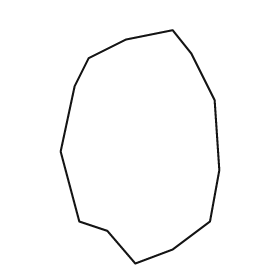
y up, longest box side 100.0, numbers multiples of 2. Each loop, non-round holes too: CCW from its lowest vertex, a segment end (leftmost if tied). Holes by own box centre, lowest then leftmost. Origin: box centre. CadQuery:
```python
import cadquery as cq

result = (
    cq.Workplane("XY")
    .moveTo(-2.0, -50.0)
    .lineTo(14.0, -44.0)
    .lineTo(30.0, -32.0)
    .lineTo(34.0, -10.0)
    .lineTo(32.0, 20.0)
    .lineTo(22.0, 40.0)
    .lineTo(14.0, 50.0)
    .lineTo(-6.0, 46.0)
    .lineTo(-22.0, 38.0)
    .lineTo(-28.0, 26.0)
    .lineTo(-34.0, -2.0)
    .lineTo(-26.0, -32.0)
    .lineTo(-14.0, -36.0)
    .close()
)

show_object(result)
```